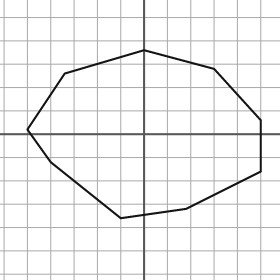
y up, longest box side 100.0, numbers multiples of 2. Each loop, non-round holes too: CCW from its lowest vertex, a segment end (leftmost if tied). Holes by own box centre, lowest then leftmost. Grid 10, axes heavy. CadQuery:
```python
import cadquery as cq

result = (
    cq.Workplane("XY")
    .moveTo(-10.0, -36.0)
    .lineTo(18.0, -32.0)
    .lineTo(50.0, -16.0)
    .lineTo(50.0, 6.0)
    .lineTo(30.0, 28.0)
    .lineTo(0.0, 36.0)
    .lineTo(-34.0, 26.0)
    .lineTo(-50.0, 2.0)
    .lineTo(-40.0, -12.0)
    .close()
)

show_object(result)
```